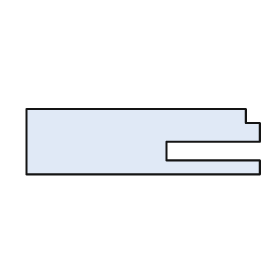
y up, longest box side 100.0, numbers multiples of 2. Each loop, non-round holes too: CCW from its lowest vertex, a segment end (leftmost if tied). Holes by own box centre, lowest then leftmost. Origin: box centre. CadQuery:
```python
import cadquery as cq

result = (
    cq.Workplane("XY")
    .moveTo(-50.0, -14.0)
    .lineTo(50.0, -14.0)
    .lineTo(50.0, -8.0)
    .lineTo(10.0, -8.0)
    .lineTo(10.0, 0.0)
    .lineTo(50.0, 0.0)
    .lineTo(50.0, 8.0)
    .lineTo(44.0, 8.0)
    .lineTo(44.0, 14.0)
    .lineTo(-50.0, 14.0)
    .close()
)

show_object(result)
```